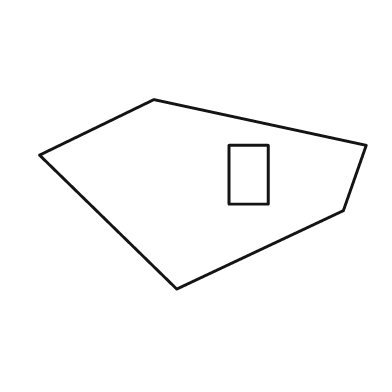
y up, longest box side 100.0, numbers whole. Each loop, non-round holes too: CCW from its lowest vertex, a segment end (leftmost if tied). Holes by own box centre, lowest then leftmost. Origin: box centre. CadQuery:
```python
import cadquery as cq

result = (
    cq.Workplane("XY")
    .moveTo(-8.0, -29.0)
    .lineTo(43.0, -5.0)
    .lineTo(50.0, 15.0)
    .lineTo(-15.0, 29.0)
    .lineTo(-50.0, 12.0)
    .close()
    .moveTo(8.0, -3.0)
    .lineTo(20.0, -3.0)
    .lineTo(20.0, 15.0)
    .lineTo(8.0, 15.0)
    .close()
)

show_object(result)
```